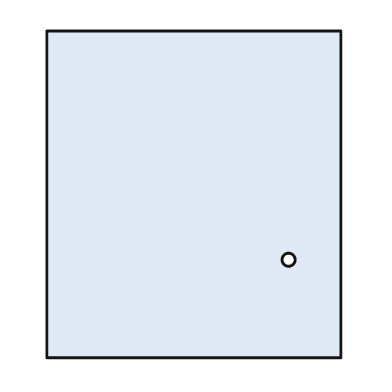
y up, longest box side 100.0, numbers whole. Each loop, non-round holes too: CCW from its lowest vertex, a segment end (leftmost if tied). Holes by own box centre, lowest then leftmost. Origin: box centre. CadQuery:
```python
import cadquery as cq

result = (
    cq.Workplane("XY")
    .moveTo(-45.0, -50.0)
    .lineTo(45.0, -50.0)
    .lineTo(45.0, 50.0)
    .lineTo(-45.0, 50.0)
    .close()
    .moveTo(29.0, -20.0)
    .circle(2.0)
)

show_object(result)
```